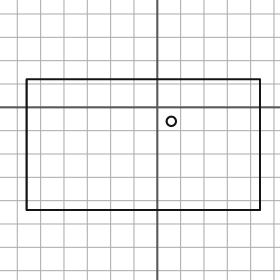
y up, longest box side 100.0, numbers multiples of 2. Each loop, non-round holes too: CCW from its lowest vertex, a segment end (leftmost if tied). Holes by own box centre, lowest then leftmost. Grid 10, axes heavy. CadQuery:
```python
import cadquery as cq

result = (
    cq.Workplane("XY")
    .moveTo(-56.0, -44.0)
    .lineTo(44.0, -44.0)
    .lineTo(44.0, 12.0)
    .lineTo(-56.0, 12.0)
    .close()
    .moveTo(6.0, -6.0)
    .circle(2.0)
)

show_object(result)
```